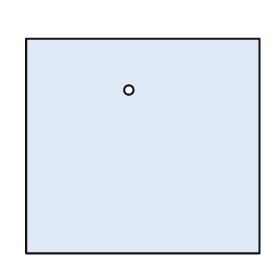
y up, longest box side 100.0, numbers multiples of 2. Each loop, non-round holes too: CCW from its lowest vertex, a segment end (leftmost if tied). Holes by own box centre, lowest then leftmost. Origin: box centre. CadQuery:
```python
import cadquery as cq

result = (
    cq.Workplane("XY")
    .moveTo(-50.0, -46.0)
    .lineTo(50.0, -46.0)
    .lineTo(50.0, 46.0)
    .lineTo(-50.0, 46.0)
    .close()
    .moveTo(-6.0, 24.0)
    .circle(2.0)
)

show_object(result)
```